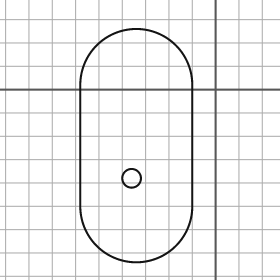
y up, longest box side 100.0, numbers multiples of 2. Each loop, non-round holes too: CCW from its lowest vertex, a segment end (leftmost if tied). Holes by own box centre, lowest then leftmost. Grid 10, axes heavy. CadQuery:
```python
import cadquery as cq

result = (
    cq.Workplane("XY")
    .moveTo(-58.0, -50.0)
    .threePointArc((-34.0, -74.0), (-10.0, -50.0))
    .lineTo(-10.0, 2.0)
    .threePointArc((-34.0, 26.0), (-58.0, 2.0))
    .close()
    .moveTo(-36.0, -38.0)
    .circle(4.0)
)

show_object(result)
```